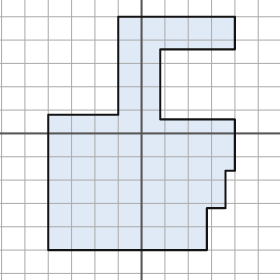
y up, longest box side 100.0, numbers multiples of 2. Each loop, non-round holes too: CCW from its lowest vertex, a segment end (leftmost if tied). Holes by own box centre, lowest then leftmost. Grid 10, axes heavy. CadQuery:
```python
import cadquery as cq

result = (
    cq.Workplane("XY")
    .moveTo(-40.0, -50.0)
    .lineTo(28.0, -50.0)
    .lineTo(28.0, -32.0)
    .lineTo(36.0, -32.0)
    .lineTo(36.0, -16.0)
    .lineTo(40.0, -16.0)
    .lineTo(40.0, 6.0)
    .lineTo(8.0, 6.0)
    .lineTo(8.0, 36.0)
    .lineTo(40.0, 36.0)
    .lineTo(40.0, 50.0)
    .lineTo(-10.0, 50.0)
    .lineTo(-10.0, 8.0)
    .lineTo(-40.0, 8.0)
    .close()
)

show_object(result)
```